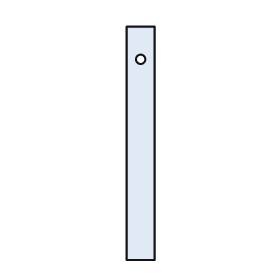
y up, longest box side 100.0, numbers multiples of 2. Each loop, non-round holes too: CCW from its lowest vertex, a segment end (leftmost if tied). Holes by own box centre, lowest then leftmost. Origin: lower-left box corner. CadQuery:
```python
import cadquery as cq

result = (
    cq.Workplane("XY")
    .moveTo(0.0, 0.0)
    .lineTo(12.0, 0.0)
    .lineTo(12.0, 100.0)
    .lineTo(0.0, 100.0)
    .close()
    .moveTo(6.0, 86.0)
    .circle(2.0)
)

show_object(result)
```